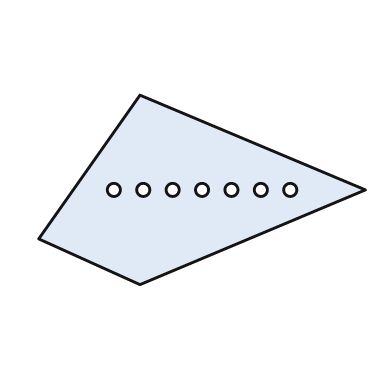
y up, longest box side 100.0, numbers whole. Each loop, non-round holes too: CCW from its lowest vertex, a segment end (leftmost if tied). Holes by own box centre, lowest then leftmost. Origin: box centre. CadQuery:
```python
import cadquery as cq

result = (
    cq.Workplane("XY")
    .moveTo(-19.0, -29.0)
    .lineTo(50.0, 0.0)
    .lineTo(-19.0, 29.0)
    .lineTo(-50.0, -15.0)
    .close()
    .moveTo(-27.0, 0.0)
    .circle(2.0)
    .moveTo(-18.0, 0.0)
    .circle(2.0)
    .moveTo(-9.0, 0.0)
    .circle(2.0)
    .moveTo(0.0, 0.0)
    .circle(2.0)
    .moveTo(9.0, 0.0)
    .circle(2.0)
    .moveTo(18.0, 0.0)
    .circle(2.0)
    .moveTo(27.0, 0.0)
    .circle(2.0)
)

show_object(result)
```